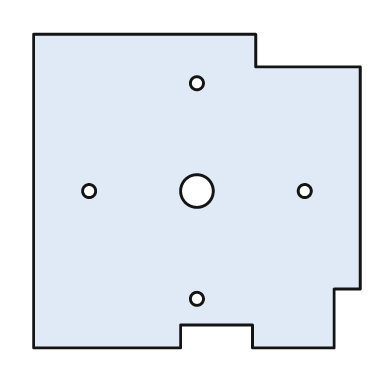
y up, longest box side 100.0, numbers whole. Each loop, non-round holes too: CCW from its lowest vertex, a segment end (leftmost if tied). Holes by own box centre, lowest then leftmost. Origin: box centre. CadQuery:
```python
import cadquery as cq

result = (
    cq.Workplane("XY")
    .moveTo(-50.0, -48.0)
    .lineTo(-5.0, -48.0)
    .lineTo(-5.0, -41.0)
    .lineTo(17.0, -41.0)
    .lineTo(17.0, -48.0)
    .lineTo(42.0, -48.0)
    .lineTo(42.0, -30.0)
    .lineTo(50.0, -30.0)
    .lineTo(50.0, 38.0)
    .lineTo(18.0, 38.0)
    .lineTo(18.0, 48.0)
    .lineTo(-50.0, 48.0)
    .close()
    .moveTo(0.0, -33.0)
    .circle(2.0)
    .moveTo(-33.0, 0.0)
    .circle(2.0)
    .moveTo(0.0, 0.0)
    .circle(5.0)
    .moveTo(33.0, 0.0)
    .circle(2.0)
    .moveTo(0.0, 33.0)
    .circle(2.0)
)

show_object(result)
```